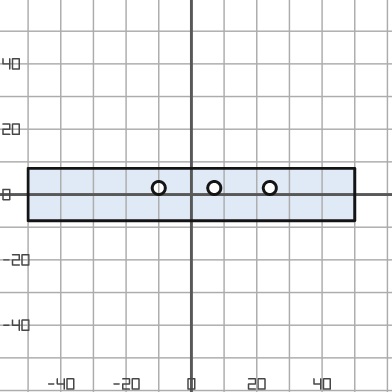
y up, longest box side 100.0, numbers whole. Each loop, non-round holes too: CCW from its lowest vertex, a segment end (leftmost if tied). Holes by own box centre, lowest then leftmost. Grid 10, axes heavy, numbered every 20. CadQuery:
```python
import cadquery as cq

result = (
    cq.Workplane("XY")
    .moveTo(-50.0, -8.0)
    .lineTo(50.0, -8.0)
    .lineTo(50.0, 8.0)
    .lineTo(-50.0, 8.0)
    .close()
    .moveTo(-10.0, 2.0)
    .circle(2.0)
    .moveTo(7.0, 2.0)
    .circle(2.0)
    .moveTo(24.0, 2.0)
    .circle(2.0)
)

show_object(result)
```